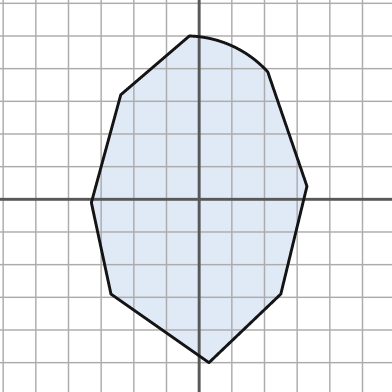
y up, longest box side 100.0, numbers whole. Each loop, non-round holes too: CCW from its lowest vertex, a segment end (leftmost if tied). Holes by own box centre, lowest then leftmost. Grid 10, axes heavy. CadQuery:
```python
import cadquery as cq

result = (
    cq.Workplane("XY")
    .moveTo(3.0, -50.0)
    .lineTo(25.0, -29.0)
    .lineTo(33.0, 4.0)
    .lineTo(21.0, 39.0)
    .threePointArc((10.0, 47.0), (-3.0, 50.0))
    .lineTo(-24.0, 32.0)
    .lineTo(-33.0, -1.0)
    .lineTo(-27.0, -29.0)
    .close()
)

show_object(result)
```